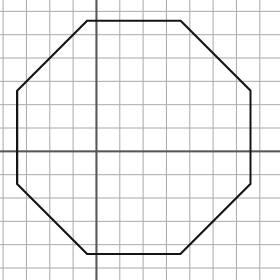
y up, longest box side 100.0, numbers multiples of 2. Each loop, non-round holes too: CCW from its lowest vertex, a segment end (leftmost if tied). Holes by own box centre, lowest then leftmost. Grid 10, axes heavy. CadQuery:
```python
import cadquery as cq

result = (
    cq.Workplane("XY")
    .moveTo(-4.0, -44.0)
    .lineTo(36.0, -44.0)
    .lineTo(66.0, -14.0)
    .lineTo(66.0, 26.0)
    .lineTo(36.0, 56.0)
    .lineTo(-4.0, 56.0)
    .lineTo(-34.0, 26.0)
    .lineTo(-34.0, -14.0)
    .close()
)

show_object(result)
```